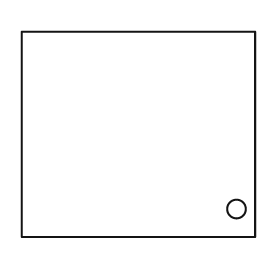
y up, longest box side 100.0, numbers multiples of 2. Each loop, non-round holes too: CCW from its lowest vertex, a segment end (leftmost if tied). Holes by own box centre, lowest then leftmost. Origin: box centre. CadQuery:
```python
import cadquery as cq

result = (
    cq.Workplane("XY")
    .moveTo(-50.0, -44.0)
    .lineTo(50.0, -44.0)
    .lineTo(50.0, 44.0)
    .lineTo(-50.0, 44.0)
    .close()
    .moveTo(42.0, -32.0)
    .circle(4.0)
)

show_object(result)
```